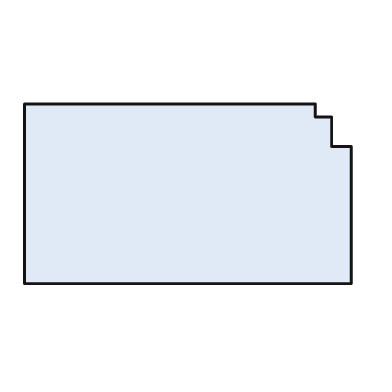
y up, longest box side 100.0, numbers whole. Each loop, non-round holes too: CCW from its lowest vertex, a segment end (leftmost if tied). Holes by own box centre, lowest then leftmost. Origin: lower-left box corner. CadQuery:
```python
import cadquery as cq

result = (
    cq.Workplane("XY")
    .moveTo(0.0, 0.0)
    .lineTo(100.0, 0.0)
    .lineTo(100.0, 42.0)
    .lineTo(94.0, 42.0)
    .lineTo(94.0, 51.0)
    .lineTo(89.0, 51.0)
    .lineTo(89.0, 55.0)
    .lineTo(0.0, 55.0)
    .close()
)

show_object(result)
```